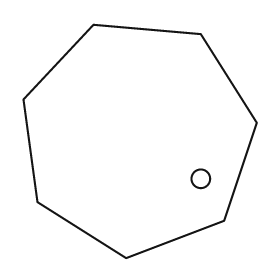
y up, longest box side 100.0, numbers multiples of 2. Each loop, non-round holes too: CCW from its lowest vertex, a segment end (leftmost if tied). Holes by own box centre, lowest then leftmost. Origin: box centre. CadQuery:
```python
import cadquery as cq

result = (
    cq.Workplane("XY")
    .moveTo(-6.0, -50.0)
    .lineTo(36.0, -34.0)
    .lineTo(50.0, 8.0)
    .lineTo(26.0, 46.0)
    .lineTo(-20.0, 50.0)
    .lineTo(-50.0, 18.0)
    .lineTo(-44.0, -26.0)
    .close()
    .moveTo(26.0, -16.0)
    .circle(4.0)
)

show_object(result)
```